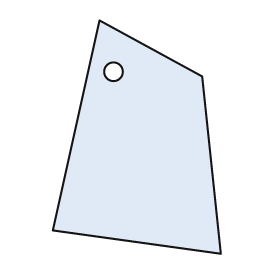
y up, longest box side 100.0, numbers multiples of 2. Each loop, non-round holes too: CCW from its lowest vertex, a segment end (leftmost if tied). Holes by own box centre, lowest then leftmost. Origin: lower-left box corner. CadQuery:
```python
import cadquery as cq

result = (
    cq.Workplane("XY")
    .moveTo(72.0, 0.0)
    .lineTo(64.0, 76.0)
    .lineTo(20.0, 100.0)
    .lineTo(0.0, 10.0)
    .close()
    .moveTo(26.0, 78.0)
    .circle(4.0)
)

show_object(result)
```